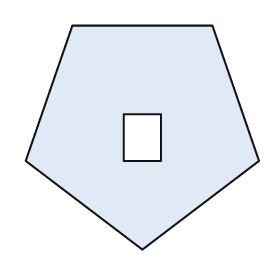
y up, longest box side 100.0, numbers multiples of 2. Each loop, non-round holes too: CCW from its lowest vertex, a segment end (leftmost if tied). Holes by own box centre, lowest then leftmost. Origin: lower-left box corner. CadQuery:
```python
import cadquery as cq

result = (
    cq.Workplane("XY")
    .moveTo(50.0, 0.0)
    .lineTo(100.0, 38.0)
    .lineTo(80.0, 96.0)
    .lineTo(20.0, 96.0)
    .lineTo(0.0, 38.0)
    .close()
    .moveTo(42.0, 38.0)
    .lineTo(58.0, 38.0)
    .lineTo(58.0, 58.0)
    .lineTo(42.0, 58.0)
    .close()
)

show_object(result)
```